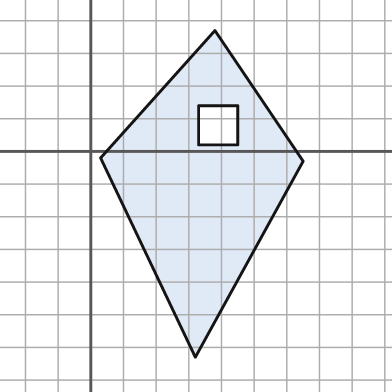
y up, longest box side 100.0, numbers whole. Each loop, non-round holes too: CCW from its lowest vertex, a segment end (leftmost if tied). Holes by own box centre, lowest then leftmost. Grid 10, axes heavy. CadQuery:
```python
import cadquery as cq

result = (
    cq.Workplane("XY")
    .moveTo(32.0, -63.0)
    .lineTo(65.0, -3.0)
    .lineTo(38.0, 37.0)
    .lineTo(3.0, -2.0)
    .close()
    .moveTo(33.0, 2.0)
    .lineTo(45.0, 2.0)
    .lineTo(45.0, 14.0)
    .lineTo(33.0, 14.0)
    .close()
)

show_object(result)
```